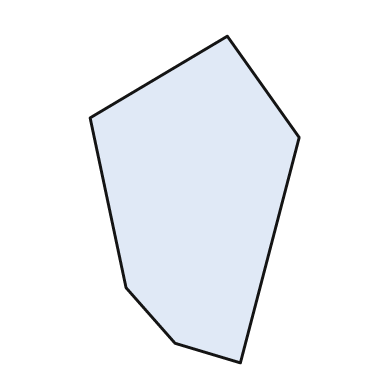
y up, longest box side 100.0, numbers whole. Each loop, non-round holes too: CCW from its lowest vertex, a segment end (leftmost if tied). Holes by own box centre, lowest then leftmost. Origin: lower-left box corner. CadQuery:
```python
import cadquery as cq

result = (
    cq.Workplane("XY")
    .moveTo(46.0, 0.0)
    .lineTo(64.0, 69.0)
    .lineTo(42.0, 100.0)
    .lineTo(0.0, 75.0)
    .lineTo(11.0, 23.0)
    .lineTo(26.0, 6.0)
    .close()
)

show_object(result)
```